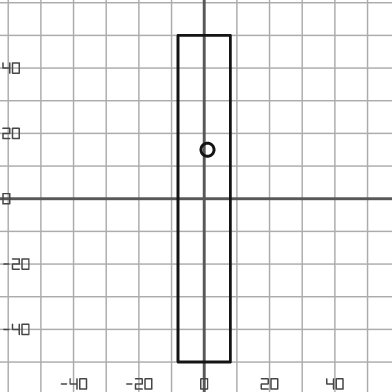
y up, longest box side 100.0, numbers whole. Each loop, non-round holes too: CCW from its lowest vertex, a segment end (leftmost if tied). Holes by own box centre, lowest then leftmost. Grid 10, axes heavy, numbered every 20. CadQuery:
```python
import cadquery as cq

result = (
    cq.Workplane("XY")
    .moveTo(-8.0, -50.0)
    .lineTo(8.0, -50.0)
    .lineTo(8.0, 50.0)
    .lineTo(-8.0, 50.0)
    .close()
    .moveTo(1.0, 15.0)
    .circle(2.0)
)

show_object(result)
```